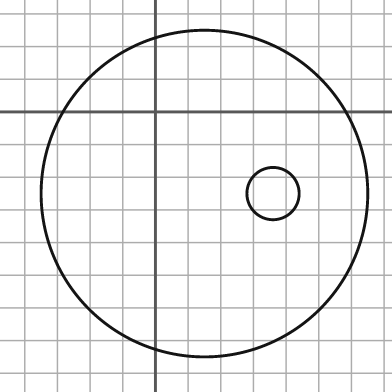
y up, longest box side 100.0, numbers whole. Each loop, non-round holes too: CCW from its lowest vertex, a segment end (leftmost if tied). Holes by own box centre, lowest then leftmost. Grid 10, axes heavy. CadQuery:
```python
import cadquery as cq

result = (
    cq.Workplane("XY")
    .moveTo(15.0, -25.0)
    .circle(50.0)
    .moveTo(36.0, -25.0)
    .circle(8.0)
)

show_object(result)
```